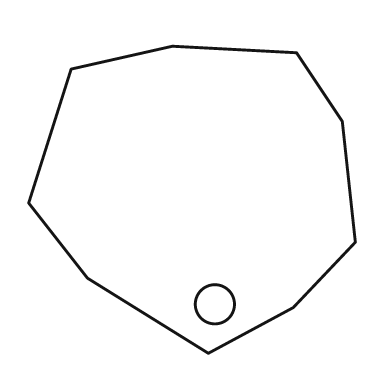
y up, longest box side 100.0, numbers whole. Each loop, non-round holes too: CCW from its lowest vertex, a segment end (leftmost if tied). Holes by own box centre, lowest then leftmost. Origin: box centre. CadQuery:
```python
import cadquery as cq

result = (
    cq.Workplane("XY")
    .moveTo(5.0, -47.0)
    .lineTo(31.0, -33.0)
    .lineTo(50.0, -13.0)
    .lineTo(46.0, 24.0)
    .lineTo(32.0, 45.0)
    .lineTo(-6.0, 47.0)
    .lineTo(-37.0, 40.0)
    .lineTo(-50.0, -1.0)
    .lineTo(-32.0, -24.0)
    .close()
    .moveTo(7.0, -32.0)
    .circle(6.0)
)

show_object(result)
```